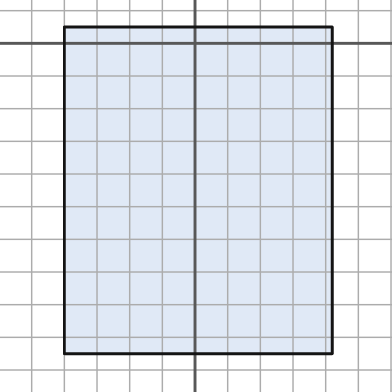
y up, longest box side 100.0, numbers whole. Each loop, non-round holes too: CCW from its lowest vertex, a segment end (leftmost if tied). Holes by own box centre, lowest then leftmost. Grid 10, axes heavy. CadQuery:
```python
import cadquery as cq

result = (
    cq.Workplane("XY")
    .moveTo(-40.0, -95.0)
    .lineTo(42.0, -95.0)
    .lineTo(42.0, 5.0)
    .lineTo(-40.0, 5.0)
    .close()
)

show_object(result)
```